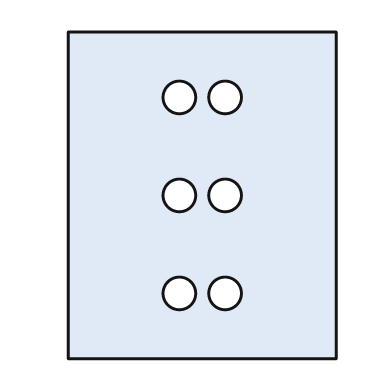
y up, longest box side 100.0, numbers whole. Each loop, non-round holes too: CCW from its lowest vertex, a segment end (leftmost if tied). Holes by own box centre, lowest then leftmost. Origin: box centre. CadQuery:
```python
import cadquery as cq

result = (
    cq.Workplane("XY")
    .moveTo(-41.0, -50.0)
    .lineTo(41.0, -50.0)
    .lineTo(41.0, 50.0)
    .lineTo(-41.0, 50.0)
    .close()
    .moveTo(-7.0, -30.0)
    .circle(5.0)
    .moveTo(7.0, -30.0)
    .circle(5.0)
    .moveTo(-7.0, 0.0)
    .circle(5.0)
    .moveTo(7.0, 0.0)
    .circle(5.0)
    .moveTo(-7.0, 30.0)
    .circle(5.0)
    .moveTo(7.0, 30.0)
    .circle(5.0)
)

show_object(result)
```